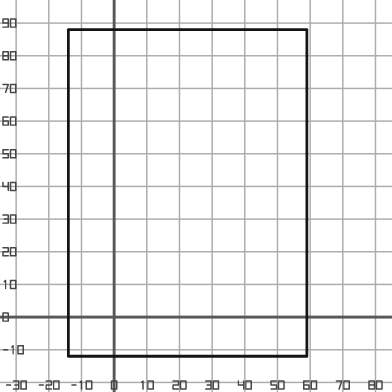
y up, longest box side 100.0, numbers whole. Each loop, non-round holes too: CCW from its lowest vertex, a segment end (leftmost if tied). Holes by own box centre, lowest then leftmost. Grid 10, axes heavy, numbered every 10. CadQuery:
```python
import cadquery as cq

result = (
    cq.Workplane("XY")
    .moveTo(-14.0, -12.0)
    .lineTo(59.0, -12.0)
    .lineTo(59.0, 88.0)
    .lineTo(-14.0, 88.0)
    .close()
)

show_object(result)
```